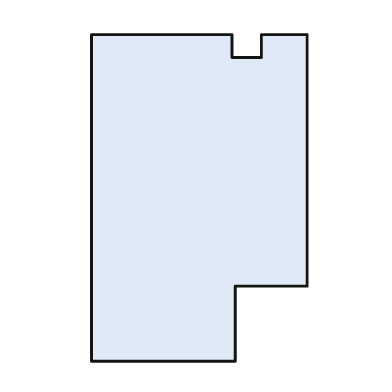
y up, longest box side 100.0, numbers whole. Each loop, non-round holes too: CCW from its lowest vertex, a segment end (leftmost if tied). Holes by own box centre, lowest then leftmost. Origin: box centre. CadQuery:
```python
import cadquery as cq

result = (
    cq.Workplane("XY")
    .moveTo(-33.0, -50.0)
    .lineTo(11.0, -50.0)
    .lineTo(11.0, -27.0)
    .lineTo(33.0, -27.0)
    .lineTo(33.0, 50.0)
    .lineTo(19.0, 50.0)
    .lineTo(19.0, 43.0)
    .lineTo(10.0, 43.0)
    .lineTo(10.0, 50.0)
    .lineTo(-33.0, 50.0)
    .close()
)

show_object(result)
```